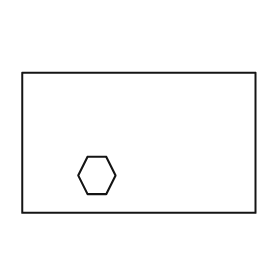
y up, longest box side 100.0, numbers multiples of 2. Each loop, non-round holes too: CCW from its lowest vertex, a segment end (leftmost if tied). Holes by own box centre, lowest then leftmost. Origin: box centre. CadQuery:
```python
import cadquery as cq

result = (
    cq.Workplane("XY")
    .moveTo(-50.0, -30.0)
    .lineTo(50.0, -30.0)
    .lineTo(50.0, 30.0)
    .lineTo(-50.0, 30.0)
    .close()
    .moveTo(-22.0, -22.0)
    .lineTo(-14.0, -22.0)
    .lineTo(-10.0, -14.0)
    .lineTo(-14.0, -6.0)
    .lineTo(-22.0, -6.0)
    .lineTo(-26.0, -14.0)
    .close()
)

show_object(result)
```